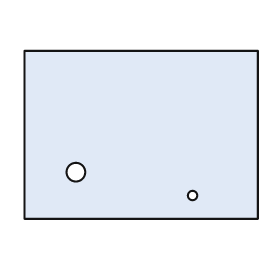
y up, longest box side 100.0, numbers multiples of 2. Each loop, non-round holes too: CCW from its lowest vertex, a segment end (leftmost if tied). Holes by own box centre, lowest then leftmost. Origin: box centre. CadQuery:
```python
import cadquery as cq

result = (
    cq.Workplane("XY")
    .moveTo(-50.0, -36.0)
    .lineTo(50.0, -36.0)
    .lineTo(50.0, 36.0)
    .lineTo(-50.0, 36.0)
    .close()
    .moveTo(22.0, -26.0)
    .circle(2.0)
    .moveTo(-28.0, -16.0)
    .circle(4.0)
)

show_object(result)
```